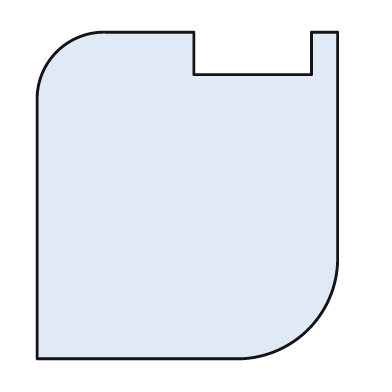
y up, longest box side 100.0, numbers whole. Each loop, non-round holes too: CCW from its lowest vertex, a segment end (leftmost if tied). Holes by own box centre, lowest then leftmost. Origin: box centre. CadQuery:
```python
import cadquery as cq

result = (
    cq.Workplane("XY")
    .moveTo(-46.0, -50.0)
    .lineTo(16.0, -50.0)
    .threePointArc((37.0, -41.0), (46.0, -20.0))
    .lineTo(46.0, 50.0)
    .lineTo(38.0, 50.0)
    .lineTo(38.0, 37.0)
    .lineTo(2.0, 37.0)
    .lineTo(2.0, 50.0)
    .lineTo(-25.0, 50.0)
    .threePointArc((-40.0, 44.0), (-46.0, 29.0))
    .close()
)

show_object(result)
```